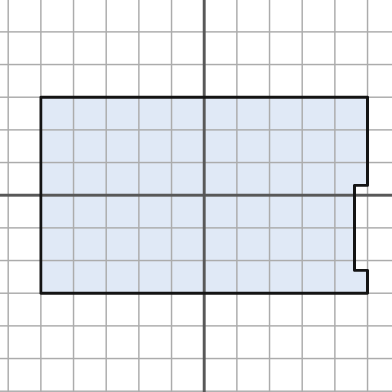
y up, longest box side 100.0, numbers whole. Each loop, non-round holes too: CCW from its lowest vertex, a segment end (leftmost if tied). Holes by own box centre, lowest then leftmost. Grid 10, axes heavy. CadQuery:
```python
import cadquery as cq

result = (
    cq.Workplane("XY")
    .moveTo(-50.0, -30.0)
    .lineTo(50.0, -30.0)
    .lineTo(50.0, -23.0)
    .lineTo(46.0, -23.0)
    .lineTo(46.0, 3.0)
    .lineTo(50.0, 3.0)
    .lineTo(50.0, 30.0)
    .lineTo(-50.0, 30.0)
    .close()
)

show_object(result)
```